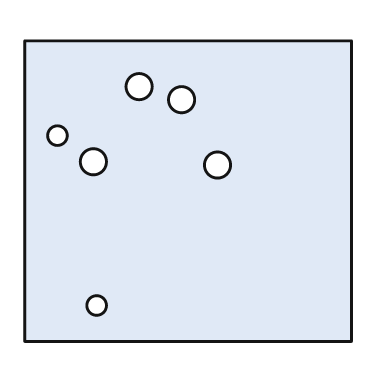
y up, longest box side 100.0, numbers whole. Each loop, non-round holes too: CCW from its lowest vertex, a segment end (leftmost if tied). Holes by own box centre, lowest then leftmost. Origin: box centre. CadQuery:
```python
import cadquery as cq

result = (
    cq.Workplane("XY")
    .moveTo(-50.0, -46.0)
    .lineTo(50.0, -46.0)
    .lineTo(50.0, 46.0)
    .lineTo(-50.0, 46.0)
    .close()
    .moveTo(-28.0, -35.0)
    .circle(3.0)
    .moveTo(9.0, 8.0)
    .circle(4.0)
    .moveTo(-29.0, 9.0)
    .circle(4.0)
    .moveTo(-40.0, 17.0)
    .circle(3.0)
    .moveTo(-2.0, 28.0)
    .circle(4.0)
    .moveTo(-15.0, 32.0)
    .circle(4.0)
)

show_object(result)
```